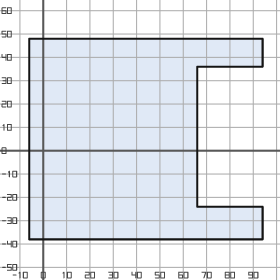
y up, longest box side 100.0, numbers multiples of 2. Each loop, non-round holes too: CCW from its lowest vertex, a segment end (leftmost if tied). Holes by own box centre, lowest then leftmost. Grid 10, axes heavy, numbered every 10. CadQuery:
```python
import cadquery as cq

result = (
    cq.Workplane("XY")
    .moveTo(-6.0, -38.0)
    .lineTo(94.0, -38.0)
    .lineTo(94.0, -24.0)
    .lineTo(66.0, -24.0)
    .lineTo(66.0, 36.0)
    .lineTo(94.0, 36.0)
    .lineTo(94.0, 48.0)
    .lineTo(-6.0, 48.0)
    .close()
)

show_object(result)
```